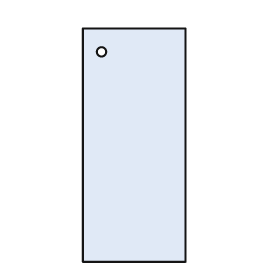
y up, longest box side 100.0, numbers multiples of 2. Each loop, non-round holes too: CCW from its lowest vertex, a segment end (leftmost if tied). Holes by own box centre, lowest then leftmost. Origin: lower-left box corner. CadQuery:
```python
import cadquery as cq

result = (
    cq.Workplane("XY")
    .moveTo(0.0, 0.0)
    .lineTo(44.0, 0.0)
    .lineTo(44.0, 100.0)
    .lineTo(0.0, 100.0)
    .close()
    .moveTo(8.0, 90.0)
    .circle(2.0)
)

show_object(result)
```